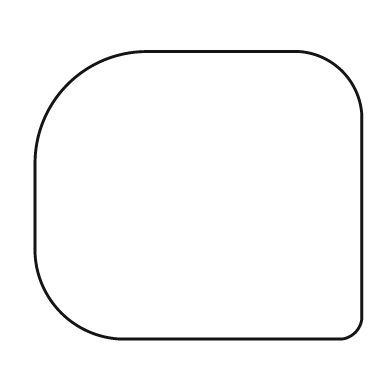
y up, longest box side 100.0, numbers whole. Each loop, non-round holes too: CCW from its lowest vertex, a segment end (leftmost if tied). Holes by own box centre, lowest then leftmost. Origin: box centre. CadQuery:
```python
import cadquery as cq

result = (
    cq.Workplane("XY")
    .moveTo(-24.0, -44.0)
    .lineTo(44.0, -44.0)
    .threePointArc((48.0, -42.0), (50.0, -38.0))
    .lineTo(50.0, 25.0)
    .threePointArc((44.0, 38.0), (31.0, 44.0))
    .lineTo(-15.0, 44.0)
    .threePointArc((-40.0, 34.0), (-50.0, 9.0))
    .lineTo(-50.0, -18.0)
    .threePointArc((-42.0, -36.0), (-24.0, -44.0))
    .close()
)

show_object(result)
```